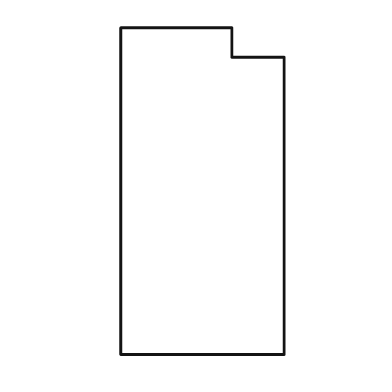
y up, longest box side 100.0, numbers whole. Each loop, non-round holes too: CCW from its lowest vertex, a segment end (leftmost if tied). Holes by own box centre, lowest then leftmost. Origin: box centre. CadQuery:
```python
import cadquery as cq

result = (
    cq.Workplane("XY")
    .moveTo(-25.0, -50.0)
    .lineTo(25.0, -50.0)
    .lineTo(25.0, 41.0)
    .lineTo(9.0, 41.0)
    .lineTo(9.0, 50.0)
    .lineTo(-25.0, 50.0)
    .close()
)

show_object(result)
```